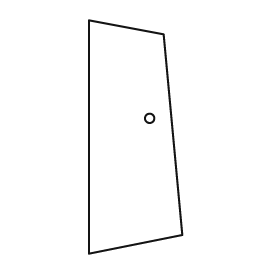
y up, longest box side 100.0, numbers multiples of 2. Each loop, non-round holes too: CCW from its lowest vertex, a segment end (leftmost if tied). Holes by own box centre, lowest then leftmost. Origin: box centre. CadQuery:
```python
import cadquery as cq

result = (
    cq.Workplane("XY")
    .moveTo(-20.0, -50.0)
    .lineTo(20.0, -42.0)
    .lineTo(12.0, 44.0)
    .lineTo(-20.0, 50.0)
    .close()
    .moveTo(6.0, 8.0)
    .circle(2.0)
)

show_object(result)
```